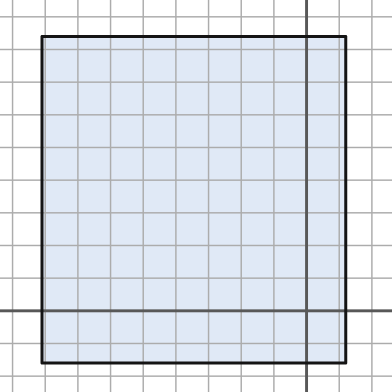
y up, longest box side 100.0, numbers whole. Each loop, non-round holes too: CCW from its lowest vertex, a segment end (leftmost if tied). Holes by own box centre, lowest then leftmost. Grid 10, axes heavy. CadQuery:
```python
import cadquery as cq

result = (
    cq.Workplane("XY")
    .moveTo(-81.0, -16.0)
    .lineTo(12.0, -16.0)
    .lineTo(12.0, 84.0)
    .lineTo(-81.0, 84.0)
    .close()
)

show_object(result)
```